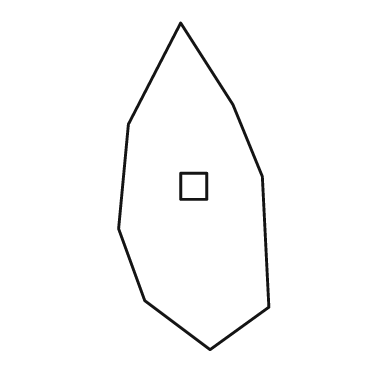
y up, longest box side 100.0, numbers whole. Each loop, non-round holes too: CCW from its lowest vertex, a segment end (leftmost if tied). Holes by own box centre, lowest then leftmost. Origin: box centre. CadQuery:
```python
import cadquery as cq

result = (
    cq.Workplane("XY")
    .moveTo(5.0, -50.0)
    .lineTo(23.0, -37.0)
    .lineTo(21.0, 3.0)
    .lineTo(12.0, 25.0)
    .lineTo(-4.0, 50.0)
    .lineTo(-20.0, 19.0)
    .lineTo(-23.0, -13.0)
    .lineTo(-15.0, -35.0)
    .close()
    .moveTo(-4.0, -4.0)
    .lineTo(4.0, -4.0)
    .lineTo(4.0, 4.0)
    .lineTo(-4.0, 4.0)
    .close()
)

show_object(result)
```